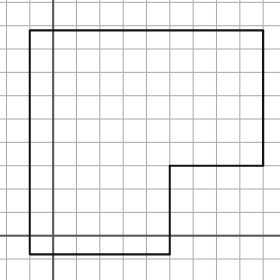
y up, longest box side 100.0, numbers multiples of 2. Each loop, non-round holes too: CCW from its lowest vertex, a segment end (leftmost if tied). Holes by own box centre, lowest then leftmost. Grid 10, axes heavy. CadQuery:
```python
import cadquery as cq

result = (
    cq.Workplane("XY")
    .moveTo(-10.0, -8.0)
    .lineTo(50.0, -8.0)
    .lineTo(50.0, 30.0)
    .lineTo(90.0, 30.0)
    .lineTo(90.0, 88.0)
    .lineTo(-10.0, 88.0)
    .close()
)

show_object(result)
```